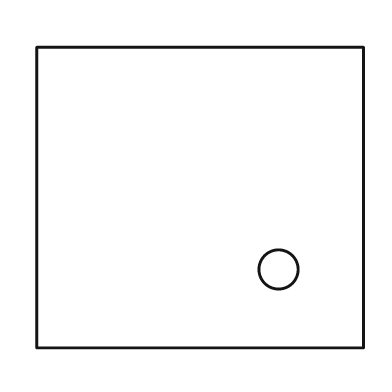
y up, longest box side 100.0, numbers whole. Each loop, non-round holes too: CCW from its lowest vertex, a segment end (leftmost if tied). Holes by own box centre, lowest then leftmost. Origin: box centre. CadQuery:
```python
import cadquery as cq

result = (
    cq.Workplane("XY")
    .moveTo(-50.0, -46.0)
    .lineTo(50.0, -46.0)
    .lineTo(50.0, 46.0)
    .lineTo(-50.0, 46.0)
    .close()
    .moveTo(24.0, -22.0)
    .circle(6.0)
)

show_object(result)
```